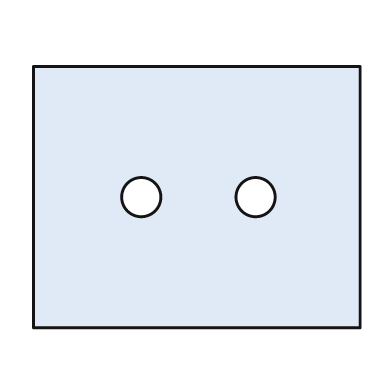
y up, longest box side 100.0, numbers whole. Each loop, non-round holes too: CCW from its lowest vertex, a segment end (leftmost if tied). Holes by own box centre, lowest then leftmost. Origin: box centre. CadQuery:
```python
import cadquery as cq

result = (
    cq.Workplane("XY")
    .moveTo(-50.0, -40.0)
    .lineTo(50.0, -40.0)
    .lineTo(50.0, 40.0)
    .lineTo(-50.0, 40.0)
    .close()
    .moveTo(-17.0, 0.0)
    .circle(6.0)
    .moveTo(18.0, 0.0)
    .circle(6.0)
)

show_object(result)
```